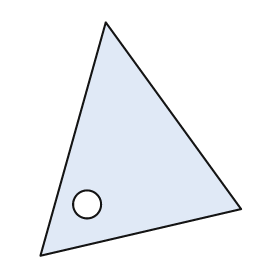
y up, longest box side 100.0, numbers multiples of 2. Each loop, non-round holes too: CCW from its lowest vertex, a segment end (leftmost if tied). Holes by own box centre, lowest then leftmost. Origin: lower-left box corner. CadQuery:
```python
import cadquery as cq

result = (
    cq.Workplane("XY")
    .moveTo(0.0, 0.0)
    .lineTo(86.0, 20.0)
    .lineTo(28.0, 100.0)
    .close()
    .moveTo(20.0, 22.0)
    .circle(6.0)
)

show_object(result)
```